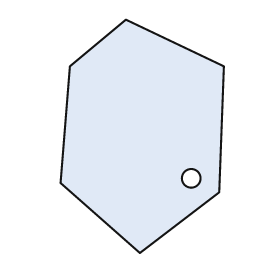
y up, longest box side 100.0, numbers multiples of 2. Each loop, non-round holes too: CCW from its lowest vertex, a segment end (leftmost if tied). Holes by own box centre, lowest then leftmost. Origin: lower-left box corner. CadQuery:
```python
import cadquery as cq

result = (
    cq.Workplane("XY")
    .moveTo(34.0, 0.0)
    .lineTo(68.0, 26.0)
    .lineTo(70.0, 80.0)
    .lineTo(28.0, 100.0)
    .lineTo(4.0, 80.0)
    .lineTo(0.0, 30.0)
    .close()
    .moveTo(56.0, 32.0)
    .circle(4.0)
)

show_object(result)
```